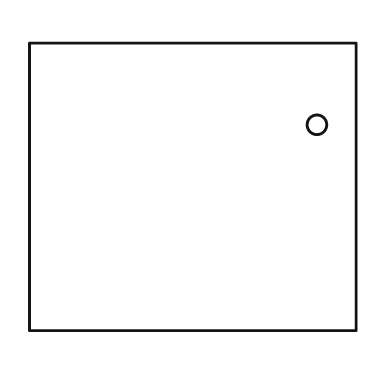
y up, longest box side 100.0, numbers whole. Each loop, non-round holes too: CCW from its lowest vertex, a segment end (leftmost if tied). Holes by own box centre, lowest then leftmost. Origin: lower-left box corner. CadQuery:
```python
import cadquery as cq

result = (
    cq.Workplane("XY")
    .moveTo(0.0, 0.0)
    .lineTo(100.0, 0.0)
    .lineTo(100.0, 88.0)
    .lineTo(0.0, 88.0)
    .close()
    .moveTo(88.0, 63.0)
    .circle(3.0)
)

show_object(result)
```